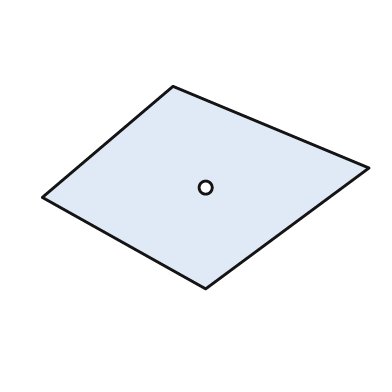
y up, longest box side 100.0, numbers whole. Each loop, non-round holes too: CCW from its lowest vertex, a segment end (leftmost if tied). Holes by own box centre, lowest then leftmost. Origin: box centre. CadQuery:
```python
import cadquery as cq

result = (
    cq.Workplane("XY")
    .moveTo(0.0, -31.0)
    .lineTo(50.0, 6.0)
    .lineTo(-10.0, 31.0)
    .lineTo(-50.0, -3.0)
    .close()
    .moveTo(0.0, 0.0)
    .circle(2.0)
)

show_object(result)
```